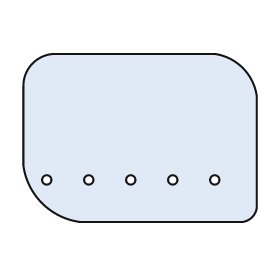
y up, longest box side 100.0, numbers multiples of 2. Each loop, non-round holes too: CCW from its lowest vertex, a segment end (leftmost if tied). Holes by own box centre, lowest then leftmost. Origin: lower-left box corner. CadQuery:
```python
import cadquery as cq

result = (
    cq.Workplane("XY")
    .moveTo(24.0, 0.0)
    .lineTo(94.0, 0.0)
    .threePointArc((98.0, 2.0), (100.0, 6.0))
    .lineTo(100.0, 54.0)
    .threePointArc((94.0, 66.0), (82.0, 72.0))
    .lineTo(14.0, 72.0)
    .threePointArc((4.0, 68.0), (0.0, 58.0))
    .lineTo(0.0, 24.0)
    .threePointArc((8.0, 8.0), (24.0, 0.0))
    .close()
    .moveTo(10.0, 18.0)
    .circle(2.0)
    .moveTo(28.0, 18.0)
    .circle(2.0)
    .moveTo(46.0, 18.0)
    .circle(2.0)
    .moveTo(64.0, 18.0)
    .circle(2.0)
    .moveTo(82.0, 18.0)
    .circle(2.0)
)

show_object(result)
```